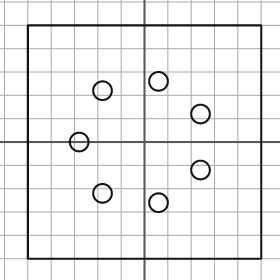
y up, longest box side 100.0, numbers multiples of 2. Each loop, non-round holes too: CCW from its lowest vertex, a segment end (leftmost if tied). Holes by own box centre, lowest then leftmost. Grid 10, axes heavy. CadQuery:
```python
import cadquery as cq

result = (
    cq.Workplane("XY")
    .moveTo(-50.0, -50.0)
    .lineTo(50.0, -50.0)
    .lineTo(50.0, 50.0)
    .lineTo(-50.0, 50.0)
    .close()
    .moveTo(6.0, -26.0)
    .circle(4.0)
    .moveTo(-18.0, -22.0)
    .circle(4.0)
    .moveTo(24.0, -12.0)
    .circle(4.0)
    .moveTo(-28.0, 0.0)
    .circle(4.0)
    .moveTo(24.0, 12.0)
    .circle(4.0)
    .moveTo(-18.0, 22.0)
    .circle(4.0)
    .moveTo(6.0, 26.0)
    .circle(4.0)
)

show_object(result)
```